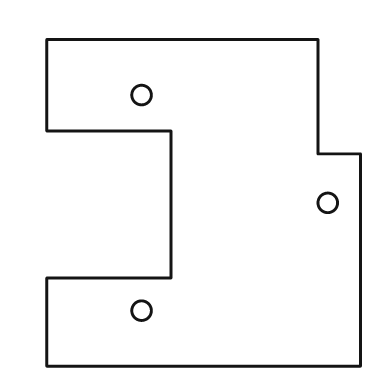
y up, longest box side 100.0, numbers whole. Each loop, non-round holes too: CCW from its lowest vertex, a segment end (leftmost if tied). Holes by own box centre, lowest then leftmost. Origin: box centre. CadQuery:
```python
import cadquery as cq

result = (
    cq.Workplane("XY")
    .moveTo(-48.0, -50.0)
    .lineTo(48.0, -50.0)
    .lineTo(48.0, 15.0)
    .lineTo(35.0, 15.0)
    .lineTo(35.0, 50.0)
    .lineTo(-48.0, 50.0)
    .lineTo(-48.0, 22.0)
    .lineTo(-10.0, 22.0)
    .lineTo(-10.0, -23.0)
    .lineTo(-48.0, -23.0)
    .close()
    .moveTo(-19.0, -33.0)
    .circle(3.0)
    .moveTo(38.0, 0.0)
    .circle(3.0)
    .moveTo(-19.0, 33.0)
    .circle(3.0)
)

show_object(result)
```